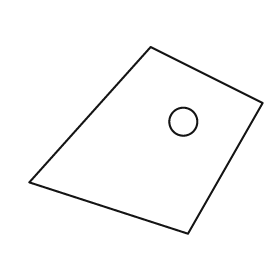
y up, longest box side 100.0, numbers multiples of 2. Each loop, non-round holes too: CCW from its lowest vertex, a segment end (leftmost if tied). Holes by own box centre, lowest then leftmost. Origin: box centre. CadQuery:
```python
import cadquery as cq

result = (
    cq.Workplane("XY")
    .moveTo(18.0, -40.0)
    .lineTo(50.0, 16.0)
    .lineTo(2.0, 40.0)
    .lineTo(-50.0, -18.0)
    .close()
    .moveTo(16.0, 8.0)
    .circle(6.0)
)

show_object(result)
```